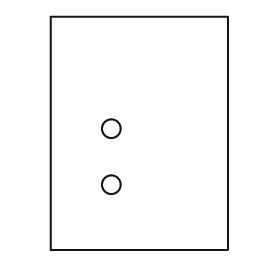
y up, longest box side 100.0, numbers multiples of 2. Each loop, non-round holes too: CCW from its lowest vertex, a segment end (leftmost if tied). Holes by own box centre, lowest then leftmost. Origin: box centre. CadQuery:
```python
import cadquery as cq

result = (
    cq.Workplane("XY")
    .moveTo(-38.0, -50.0)
    .lineTo(38.0, -50.0)
    .lineTo(38.0, 50.0)
    .lineTo(-38.0, 50.0)
    .close()
    .moveTo(-12.0, -22.0)
    .circle(4.0)
    .moveTo(-12.0, 2.0)
    .circle(4.0)
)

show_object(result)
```